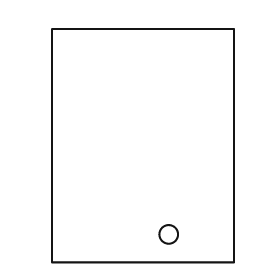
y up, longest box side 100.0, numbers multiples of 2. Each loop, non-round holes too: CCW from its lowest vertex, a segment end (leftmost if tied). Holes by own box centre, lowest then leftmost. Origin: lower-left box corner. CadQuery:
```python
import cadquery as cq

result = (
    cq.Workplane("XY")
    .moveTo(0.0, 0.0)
    .lineTo(78.0, 0.0)
    .lineTo(78.0, 100.0)
    .lineTo(0.0, 100.0)
    .close()
    .moveTo(50.0, 12.0)
    .circle(4.0)
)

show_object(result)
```